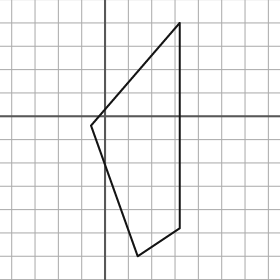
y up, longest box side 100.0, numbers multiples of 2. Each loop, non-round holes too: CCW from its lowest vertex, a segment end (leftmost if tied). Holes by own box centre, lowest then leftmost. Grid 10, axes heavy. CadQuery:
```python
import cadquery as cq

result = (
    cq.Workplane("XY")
    .moveTo(14.0, -60.0)
    .lineTo(32.0, -48.0)
    .lineTo(32.0, 40.0)
    .lineTo(-6.0, -4.0)
    .close()
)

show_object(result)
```